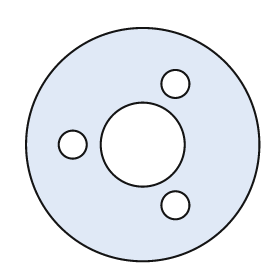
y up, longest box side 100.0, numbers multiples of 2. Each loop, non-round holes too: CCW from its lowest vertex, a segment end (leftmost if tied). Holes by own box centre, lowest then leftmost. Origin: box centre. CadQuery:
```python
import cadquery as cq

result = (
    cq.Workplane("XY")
    .moveTo(0.0, 0.0)
    .circle(50.0)
    .moveTo(14.0, -26.0)
    .circle(6.0)
    .moveTo(-30.0, 0.0)
    .circle(6.0)
    .moveTo(0.0, 0.0)
    .circle(18.0)
    .moveTo(14.0, 26.0)
    .circle(6.0)
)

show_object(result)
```